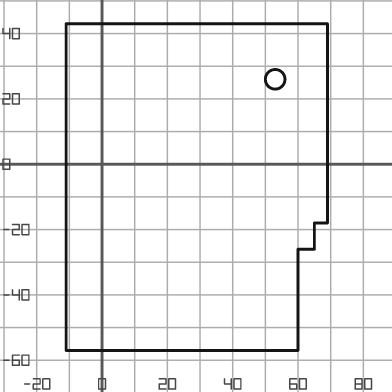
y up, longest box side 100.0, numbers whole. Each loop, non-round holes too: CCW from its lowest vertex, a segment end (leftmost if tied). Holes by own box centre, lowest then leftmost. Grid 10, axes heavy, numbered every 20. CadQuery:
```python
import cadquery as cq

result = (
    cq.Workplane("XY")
    .moveTo(-11.0, -57.0)
    .lineTo(60.0, -57.0)
    .lineTo(60.0, -26.0)
    .lineTo(65.0, -26.0)
    .lineTo(65.0, -18.0)
    .lineTo(69.0, -18.0)
    .lineTo(69.0, 43.0)
    .lineTo(-11.0, 43.0)
    .close()
    .moveTo(53.0, 26.0)
    .circle(3.0)
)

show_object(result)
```